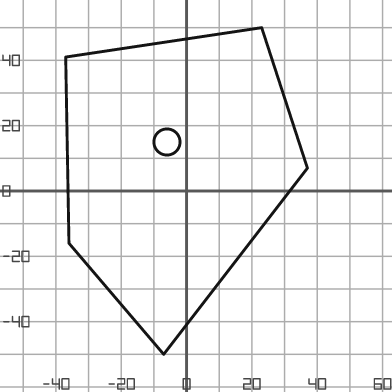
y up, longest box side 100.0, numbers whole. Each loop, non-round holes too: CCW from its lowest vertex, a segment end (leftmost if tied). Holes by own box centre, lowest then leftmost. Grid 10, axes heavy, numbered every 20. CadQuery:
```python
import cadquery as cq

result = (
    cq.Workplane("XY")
    .moveTo(-7.0, -50.0)
    .lineTo(37.0, 7.0)
    .lineTo(23.0, 50.0)
    .lineTo(-37.0, 41.0)
    .lineTo(-36.0, -16.0)
    .close()
    .moveTo(-6.0, 15.0)
    .circle(4.0)
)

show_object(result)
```